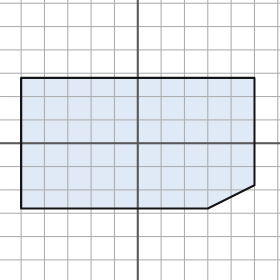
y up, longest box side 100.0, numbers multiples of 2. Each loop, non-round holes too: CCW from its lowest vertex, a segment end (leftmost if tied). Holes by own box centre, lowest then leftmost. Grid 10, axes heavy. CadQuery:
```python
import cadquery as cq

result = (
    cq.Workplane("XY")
    .moveTo(-50.0, -28.0)
    .lineTo(30.0, -28.0)
    .lineTo(50.0, -18.0)
    .lineTo(50.0, 28.0)
    .lineTo(-50.0, 28.0)
    .close()
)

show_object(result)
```